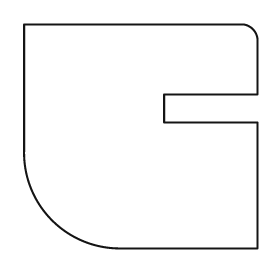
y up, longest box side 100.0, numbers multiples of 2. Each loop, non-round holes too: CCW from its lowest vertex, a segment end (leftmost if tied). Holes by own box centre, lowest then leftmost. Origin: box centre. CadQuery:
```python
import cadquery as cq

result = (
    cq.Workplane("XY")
    .moveTo(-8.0, -48.0)
    .lineTo(50.0, -48.0)
    .lineTo(50.0, 6.0)
    .lineTo(10.0, 6.0)
    .lineTo(10.0, 18.0)
    .lineTo(50.0, 18.0)
    .lineTo(50.0, 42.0)
    .threePointArc((48.0, 46.0), (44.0, 48.0))
    .lineTo(-50.0, 48.0)
    .lineTo(-50.0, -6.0)
    .threePointArc((-38.0, -36.0), (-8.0, -48.0))
    .close()
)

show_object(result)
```